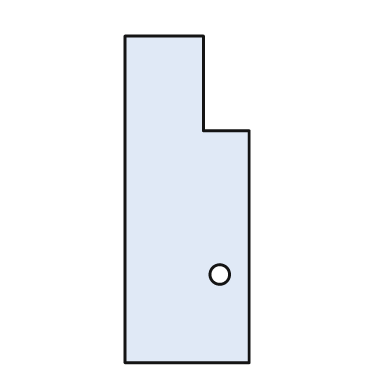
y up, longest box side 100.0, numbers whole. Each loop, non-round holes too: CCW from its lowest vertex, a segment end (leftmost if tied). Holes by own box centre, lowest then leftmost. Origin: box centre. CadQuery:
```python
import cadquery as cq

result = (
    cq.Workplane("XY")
    .moveTo(-19.0, -50.0)
    .lineTo(19.0, -50.0)
    .lineTo(19.0, 21.0)
    .lineTo(5.0, 21.0)
    .lineTo(5.0, 50.0)
    .lineTo(-19.0, 50.0)
    .close()
    .moveTo(10.0, -23.0)
    .circle(3.0)
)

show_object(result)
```